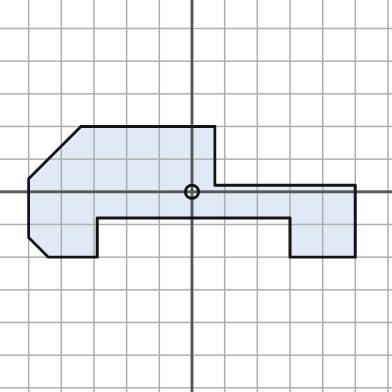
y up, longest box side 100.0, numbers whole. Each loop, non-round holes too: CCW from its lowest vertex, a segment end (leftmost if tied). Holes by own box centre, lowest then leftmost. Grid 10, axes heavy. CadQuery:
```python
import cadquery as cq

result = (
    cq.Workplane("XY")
    .moveTo(-44.0, -20.0)
    .lineTo(-29.0, -20.0)
    .lineTo(-29.0, -8.0)
    .lineTo(30.0, -8.0)
    .lineTo(30.0, -20.0)
    .lineTo(50.0, -20.0)
    .lineTo(50.0, 2.0)
    .lineTo(7.0, 2.0)
    .lineTo(7.0, 20.0)
    .lineTo(-34.0, 20.0)
    .lineTo(-50.0, 4.0)
    .lineTo(-50.0, -14.0)
    .close()
    .moveTo(0.0, 0.0)
    .circle(2.0)
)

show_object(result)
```